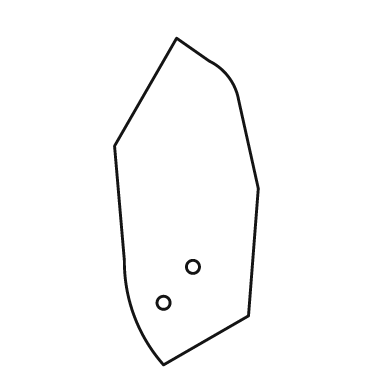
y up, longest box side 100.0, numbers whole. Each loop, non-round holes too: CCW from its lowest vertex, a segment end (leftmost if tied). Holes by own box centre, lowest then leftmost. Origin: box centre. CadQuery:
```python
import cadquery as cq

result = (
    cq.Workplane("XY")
    .moveTo(-7.0, -50.0)
    .lineTo(19.0, -35.0)
    .lineTo(22.0, 4.0)
    .lineTo(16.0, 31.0)
    .threePointArc((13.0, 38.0), (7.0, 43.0))
    .lineTo(-3.0, 50.0)
    .lineTo(-22.0, 17.0)
    .lineTo(-19.0, -18.0)
    .threePointArc((-16.0, -35.0), (-7.0, -50.0))
    .close()
    .moveTo(-7.0, -31.0)
    .circle(2.0)
    .moveTo(2.0, -20.0)
    .circle(2.0)
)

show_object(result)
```